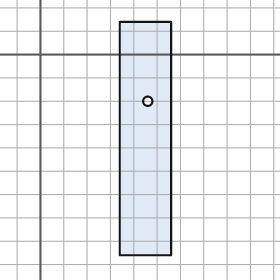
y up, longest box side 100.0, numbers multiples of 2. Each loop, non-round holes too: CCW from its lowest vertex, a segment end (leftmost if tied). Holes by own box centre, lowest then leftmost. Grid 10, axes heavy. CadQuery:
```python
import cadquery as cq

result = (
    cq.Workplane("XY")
    .moveTo(34.0, -86.0)
    .lineTo(56.0, -86.0)
    .lineTo(56.0, 14.0)
    .lineTo(34.0, 14.0)
    .close()
    .moveTo(46.0, -20.0)
    .circle(2.0)
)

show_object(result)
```